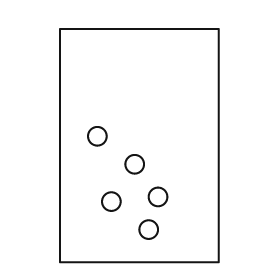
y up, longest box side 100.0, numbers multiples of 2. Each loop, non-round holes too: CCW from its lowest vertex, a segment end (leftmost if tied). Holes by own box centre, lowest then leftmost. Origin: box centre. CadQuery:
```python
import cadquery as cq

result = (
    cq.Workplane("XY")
    .moveTo(-34.0, -50.0)
    .lineTo(34.0, -50.0)
    .lineTo(34.0, 50.0)
    .lineTo(-34.0, 50.0)
    .close()
    .moveTo(4.0, -36.0)
    .circle(4.0)
    .moveTo(-12.0, -24.0)
    .circle(4.0)
    .moveTo(8.0, -22.0)
    .circle(4.0)
    .moveTo(-2.0, -8.0)
    .circle(4.0)
    .moveTo(-18.0, 4.0)
    .circle(4.0)
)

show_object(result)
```